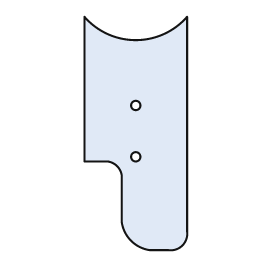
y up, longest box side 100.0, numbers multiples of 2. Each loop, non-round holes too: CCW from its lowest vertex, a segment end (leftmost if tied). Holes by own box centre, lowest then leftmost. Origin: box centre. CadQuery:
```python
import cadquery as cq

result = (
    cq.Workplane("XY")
    .moveTo(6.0, -50.0)
    .lineTo(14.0, -50.0)
    .threePointArc((20.0, -48.0), (22.0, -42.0))
    .lineTo(22.0, 50.0)
    .threePointArc((0.0, 40.0), (-22.0, 50.0))
    .lineTo(-22.0, -12.0)
    .lineTo(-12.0, -12.0)
    .threePointArc((-8.0, -14.0), (-6.0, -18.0))
    .lineTo(-6.0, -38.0)
    .threePointArc((-2.0, -46.0), (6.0, -50.0))
    .close()
    .moveTo(0.0, -10.0)
    .circle(2.0)
    .moveTo(0.0, 12.0)
    .circle(2.0)
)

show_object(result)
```